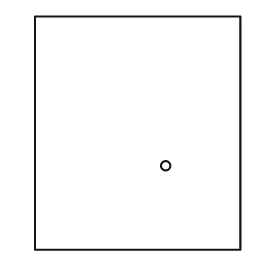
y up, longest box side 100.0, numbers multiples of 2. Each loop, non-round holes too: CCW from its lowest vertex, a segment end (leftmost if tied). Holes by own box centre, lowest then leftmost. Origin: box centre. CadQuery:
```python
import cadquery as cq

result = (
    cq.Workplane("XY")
    .moveTo(-44.0, -50.0)
    .lineTo(44.0, -50.0)
    .lineTo(44.0, 50.0)
    .lineTo(-44.0, 50.0)
    .close()
    .moveTo(12.0, -14.0)
    .circle(2.0)
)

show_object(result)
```